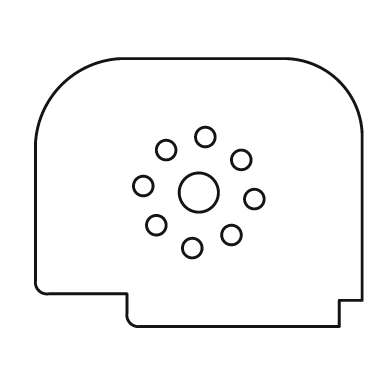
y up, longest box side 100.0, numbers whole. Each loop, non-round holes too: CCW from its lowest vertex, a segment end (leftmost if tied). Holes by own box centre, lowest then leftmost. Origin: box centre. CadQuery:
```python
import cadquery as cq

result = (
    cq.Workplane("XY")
    .moveTo(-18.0, -41.0)
    .lineTo(43.0, -41.0)
    .lineTo(43.0, -33.0)
    .lineTo(50.0, -33.0)
    .lineTo(50.0, 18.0)
    .threePointArc((43.0, 34.0), (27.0, 41.0))
    .lineTo(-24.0, 41.0)
    .threePointArc((-42.0, 33.0), (-50.0, 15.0))
    .lineTo(-50.0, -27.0)
    .threePointArc((-49.0, -30.0), (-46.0, -31.0))
    .lineTo(-22.0, -31.0)
    .lineTo(-22.0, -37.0)
    .threePointArc((-21.0, -40.0), (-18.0, -41.0))
    .close()
    .moveTo(-2.0, -17.0)
    .circle(3.0)
    .moveTo(10.0, -13.0)
    .circle(3.0)
    .moveTo(-13.0, -10.0)
    .circle(3.0)
    .moveTo(17.0, -2.0)
    .circle(3.0)
    .moveTo(0.0, 0.0)
    .circle(6.0)
    .moveTo(-17.0, 2.0)
    .circle(3.0)
    .moveTo(13.0, 10.0)
    .circle(3.0)
    .moveTo(-10.0, 13.0)
    .circle(3.0)
    .moveTo(2.0, 17.0)
    .circle(3.0)
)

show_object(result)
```